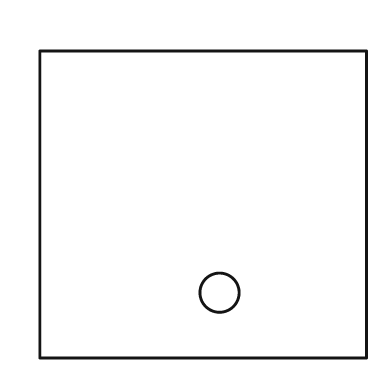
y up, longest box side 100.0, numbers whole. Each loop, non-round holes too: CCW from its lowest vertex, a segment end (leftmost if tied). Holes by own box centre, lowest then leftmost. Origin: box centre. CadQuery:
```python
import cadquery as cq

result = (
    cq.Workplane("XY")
    .moveTo(-50.0, -47.0)
    .lineTo(50.0, -47.0)
    .lineTo(50.0, 47.0)
    .lineTo(-50.0, 47.0)
    .close()
    .moveTo(5.0, -27.0)
    .circle(6.0)
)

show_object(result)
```